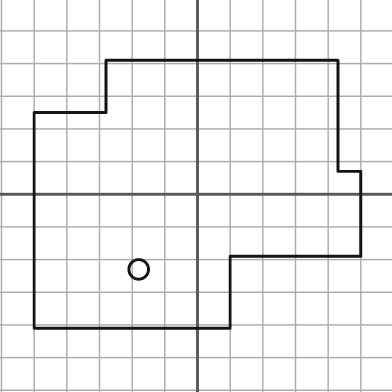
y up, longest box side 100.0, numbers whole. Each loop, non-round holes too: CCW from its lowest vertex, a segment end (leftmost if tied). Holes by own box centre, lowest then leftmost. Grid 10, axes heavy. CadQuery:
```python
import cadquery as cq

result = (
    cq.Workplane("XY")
    .moveTo(-50.0, -41.0)
    .lineTo(10.0, -41.0)
    .lineTo(10.0, -19.0)
    .lineTo(50.0, -19.0)
    .lineTo(50.0, 7.0)
    .lineTo(43.0, 7.0)
    .lineTo(43.0, 41.0)
    .lineTo(-28.0, 41.0)
    .lineTo(-28.0, 25.0)
    .lineTo(-50.0, 25.0)
    .close()
    .moveTo(-18.0, -23.0)
    .circle(3.0)
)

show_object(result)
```